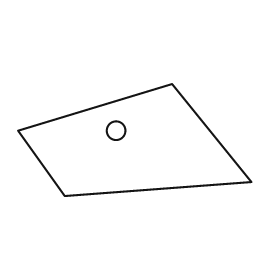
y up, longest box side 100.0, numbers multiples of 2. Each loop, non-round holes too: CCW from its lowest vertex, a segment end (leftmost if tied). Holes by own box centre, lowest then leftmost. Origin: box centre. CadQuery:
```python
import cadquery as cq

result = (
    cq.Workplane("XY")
    .moveTo(-30.0, -24.0)
    .lineTo(50.0, -18.0)
    .lineTo(16.0, 24.0)
    .lineTo(-50.0, 4.0)
    .close()
    .moveTo(-8.0, 4.0)
    .circle(4.0)
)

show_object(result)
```